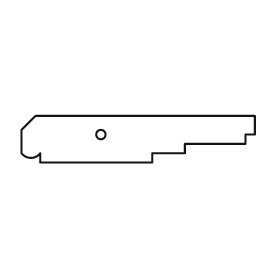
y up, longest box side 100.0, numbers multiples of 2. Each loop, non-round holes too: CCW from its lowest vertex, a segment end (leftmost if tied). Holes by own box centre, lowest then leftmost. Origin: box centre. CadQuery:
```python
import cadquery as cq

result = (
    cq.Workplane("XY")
    .moveTo(-42.0, -10.0)
    .lineTo(6.0, -10.0)
    .lineTo(6.0, -6.0)
    .lineTo(20.0, -6.0)
    .lineTo(20.0, -2.0)
    .lineTo(46.0, -2.0)
    .lineTo(46.0, 2.0)
    .lineTo(50.0, 2.0)
    .lineTo(50.0, 10.0)
    .lineTo(-44.0, 10.0)
    .lineTo(-50.0, 4.0)
    .lineTo(-50.0, -6.0)
    .threePointArc((-46.0, -8.0), (-42.0, -6.0))
    .close()
    .moveTo(-16.0, 2.0)
    .circle(2.0)
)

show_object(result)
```